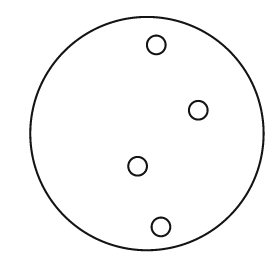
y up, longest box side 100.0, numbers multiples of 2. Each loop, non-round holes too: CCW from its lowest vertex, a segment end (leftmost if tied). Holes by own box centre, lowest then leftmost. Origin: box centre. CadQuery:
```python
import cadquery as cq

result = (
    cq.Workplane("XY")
    .moveTo(0.0, 0.0)
    .circle(50.0)
    .moveTo(6.0, -40.0)
    .circle(4.0)
    .moveTo(-4.0, -14.0)
    .circle(4.0)
    .moveTo(22.0, 10.0)
    .circle(4.0)
    .moveTo(4.0, 38.0)
    .circle(4.0)
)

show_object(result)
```